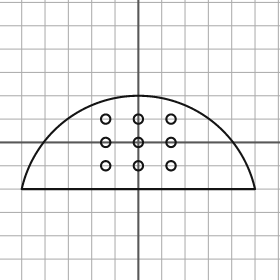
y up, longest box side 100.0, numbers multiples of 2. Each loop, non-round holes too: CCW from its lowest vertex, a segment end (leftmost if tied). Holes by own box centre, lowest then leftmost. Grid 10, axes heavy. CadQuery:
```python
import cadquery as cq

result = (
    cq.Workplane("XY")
    .moveTo(-50.0, -20.0)
    .lineTo(50.0, -20.0)
    .threePointArc((0.0, 20.0), (-50.0, -20.0))
    .close()
    .moveTo(-14.0, -10.0)
    .circle(2.0)
    .moveTo(0.0, -10.0)
    .circle(2.0)
    .moveTo(14.0, -10.0)
    .circle(2.0)
    .moveTo(-14.0, 0.0)
    .circle(2.0)
    .moveTo(0.0, 0.0)
    .circle(2.0)
    .moveTo(14.0, 0.0)
    .circle(2.0)
    .moveTo(-14.0, 10.0)
    .circle(2.0)
    .moveTo(0.0, 10.0)
    .circle(2.0)
    .moveTo(14.0, 10.0)
    .circle(2.0)
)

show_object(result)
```